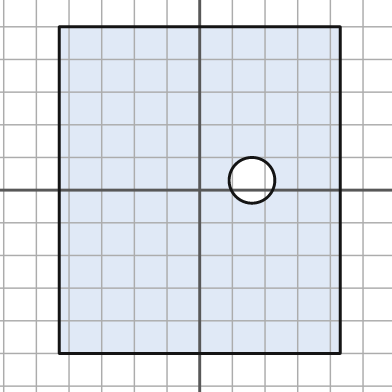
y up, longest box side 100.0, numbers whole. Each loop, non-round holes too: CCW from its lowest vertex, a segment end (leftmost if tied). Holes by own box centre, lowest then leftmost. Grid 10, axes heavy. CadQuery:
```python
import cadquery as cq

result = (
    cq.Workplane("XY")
    .moveTo(-43.0, -50.0)
    .lineTo(43.0, -50.0)
    .lineTo(43.0, 50.0)
    .lineTo(-43.0, 50.0)
    .close()
    .moveTo(16.0, 3.0)
    .circle(7.0)
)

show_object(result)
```